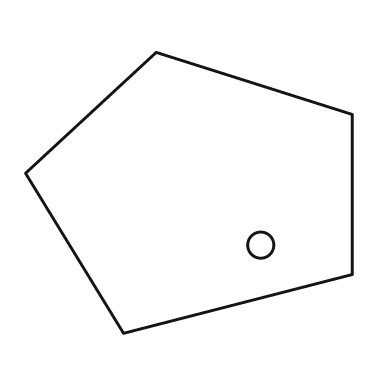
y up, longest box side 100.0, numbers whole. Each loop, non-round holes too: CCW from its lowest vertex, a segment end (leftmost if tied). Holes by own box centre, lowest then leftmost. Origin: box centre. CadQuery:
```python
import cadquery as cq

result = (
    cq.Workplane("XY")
    .moveTo(-20.0, -43.0)
    .lineTo(50.0, -25.0)
    .lineTo(50.0, 24.0)
    .lineTo(-10.0, 43.0)
    .lineTo(-50.0, 6.0)
    .close()
    .moveTo(22.0, -16.0)
    .circle(4.0)
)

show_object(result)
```